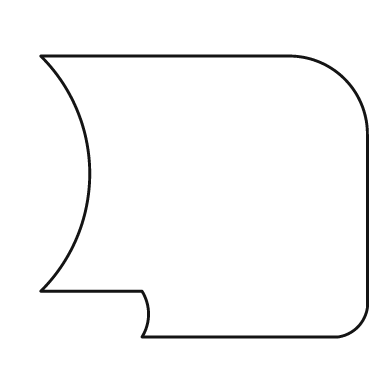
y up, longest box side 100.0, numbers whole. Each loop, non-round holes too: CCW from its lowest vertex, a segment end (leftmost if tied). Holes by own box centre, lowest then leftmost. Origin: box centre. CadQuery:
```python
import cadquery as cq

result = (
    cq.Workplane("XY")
    .moveTo(-19.0, -43.0)
    .lineTo(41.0, -43.0)
    .threePointArc((47.0, -40.0), (50.0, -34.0))
    .lineTo(50.0, 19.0)
    .threePointArc((43.0, 36.0), (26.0, 43.0))
    .lineTo(-50.0, 43.0)
    .threePointArc((-35.0, 7.0), (-50.0, -29.0))
    .lineTo(-19.0, -29.0)
    .threePointArc((-17.0, -36.0), (-19.0, -43.0))
    .close()
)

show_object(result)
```